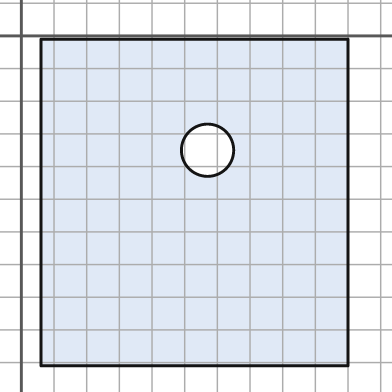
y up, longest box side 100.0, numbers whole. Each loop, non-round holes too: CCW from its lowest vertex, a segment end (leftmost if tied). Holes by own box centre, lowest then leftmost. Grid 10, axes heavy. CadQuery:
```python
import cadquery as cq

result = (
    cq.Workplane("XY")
    .moveTo(6.0, -101.0)
    .lineTo(100.0, -101.0)
    .lineTo(100.0, -1.0)
    .lineTo(6.0, -1.0)
    .close()
    .moveTo(57.0, -35.0)
    .circle(8.0)
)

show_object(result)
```